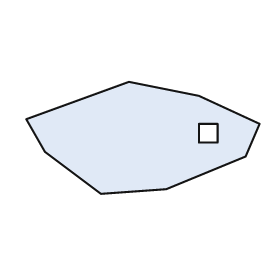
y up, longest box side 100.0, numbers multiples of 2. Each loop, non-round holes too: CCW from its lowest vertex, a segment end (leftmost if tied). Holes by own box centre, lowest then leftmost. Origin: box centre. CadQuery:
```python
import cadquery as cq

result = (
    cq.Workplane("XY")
    .moveTo(-18.0, -24.0)
    .lineTo(10.0, -22.0)
    .lineTo(44.0, -8.0)
    .lineTo(50.0, 6.0)
    .lineTo(24.0, 18.0)
    .lineTo(-6.0, 24.0)
    .lineTo(-50.0, 8.0)
    .lineTo(-42.0, -6.0)
    .close()
    .moveTo(24.0, -2.0)
    .lineTo(32.0, -2.0)
    .lineTo(32.0, 6.0)
    .lineTo(24.0, 6.0)
    .close()
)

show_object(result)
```